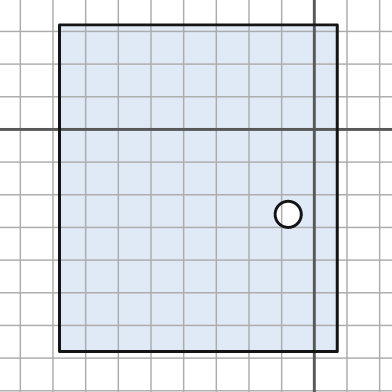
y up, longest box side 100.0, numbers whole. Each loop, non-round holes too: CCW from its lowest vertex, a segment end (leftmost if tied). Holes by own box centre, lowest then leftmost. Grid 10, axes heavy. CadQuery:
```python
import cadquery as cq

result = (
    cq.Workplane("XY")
    .moveTo(-78.0, -68.0)
    .lineTo(7.0, -68.0)
    .lineTo(7.0, 32.0)
    .lineTo(-78.0, 32.0)
    .close()
    .moveTo(-8.0, -26.0)
    .circle(4.0)
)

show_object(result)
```